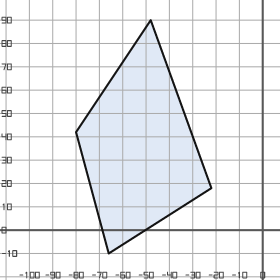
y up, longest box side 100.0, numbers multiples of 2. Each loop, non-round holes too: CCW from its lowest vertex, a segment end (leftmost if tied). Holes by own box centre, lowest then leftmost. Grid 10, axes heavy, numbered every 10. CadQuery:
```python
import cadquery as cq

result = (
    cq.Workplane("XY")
    .moveTo(-66.0, -10.0)
    .lineTo(-22.0, 18.0)
    .lineTo(-48.0, 90.0)
    .lineTo(-80.0, 42.0)
    .close()
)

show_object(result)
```